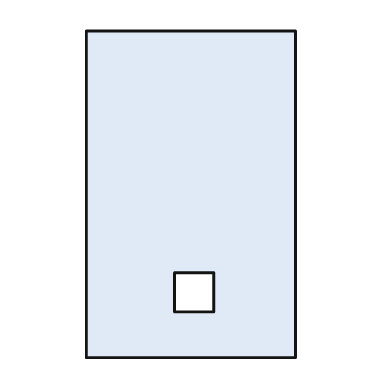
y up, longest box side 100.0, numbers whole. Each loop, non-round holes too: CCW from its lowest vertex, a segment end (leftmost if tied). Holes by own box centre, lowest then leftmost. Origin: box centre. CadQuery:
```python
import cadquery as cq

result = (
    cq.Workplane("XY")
    .moveTo(-32.0, -50.0)
    .lineTo(32.0, -50.0)
    .lineTo(32.0, 50.0)
    .lineTo(-32.0, 50.0)
    .close()
    .moveTo(-5.0, -36.0)
    .lineTo(7.0, -36.0)
    .lineTo(7.0, -24.0)
    .lineTo(-5.0, -24.0)
    .close()
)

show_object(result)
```